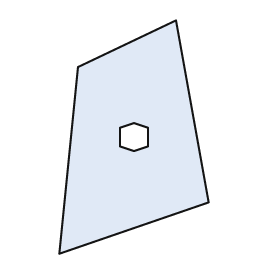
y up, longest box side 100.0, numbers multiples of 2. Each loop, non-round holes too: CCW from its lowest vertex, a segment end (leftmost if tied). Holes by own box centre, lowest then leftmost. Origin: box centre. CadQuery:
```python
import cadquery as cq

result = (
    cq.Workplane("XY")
    .moveTo(-32.0, -50.0)
    .lineTo(32.0, -28.0)
    .lineTo(18.0, 50.0)
    .lineTo(-24.0, 30.0)
    .close()
    .moveTo(0.0, -6.0)
    .lineTo(6.0, -4.0)
    .lineTo(6.0, 4.0)
    .lineTo(0.0, 6.0)
    .lineTo(-6.0, 4.0)
    .lineTo(-6.0, -4.0)
    .close()
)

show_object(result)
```